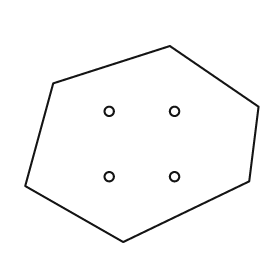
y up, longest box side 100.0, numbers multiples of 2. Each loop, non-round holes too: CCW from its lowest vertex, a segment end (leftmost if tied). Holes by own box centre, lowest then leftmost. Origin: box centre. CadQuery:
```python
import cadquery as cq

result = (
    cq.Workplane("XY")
    .moveTo(-8.0, -42.0)
    .lineTo(46.0, -16.0)
    .lineTo(50.0, 16.0)
    .lineTo(12.0, 42.0)
    .lineTo(-38.0, 26.0)
    .lineTo(-50.0, -18.0)
    .close()
    .moveTo(-14.0, -14.0)
    .circle(2.0)
    .moveTo(14.0, -14.0)
    .circle(2.0)
    .moveTo(-14.0, 14.0)
    .circle(2.0)
    .moveTo(14.0, 14.0)
    .circle(2.0)
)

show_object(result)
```